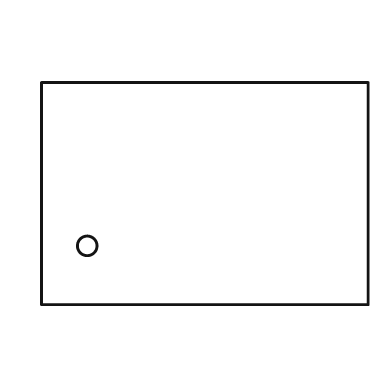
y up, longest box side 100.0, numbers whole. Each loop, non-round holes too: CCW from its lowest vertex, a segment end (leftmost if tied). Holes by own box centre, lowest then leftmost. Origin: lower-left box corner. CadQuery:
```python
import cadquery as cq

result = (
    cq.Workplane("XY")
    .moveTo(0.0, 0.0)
    .lineTo(100.0, 0.0)
    .lineTo(100.0, 68.0)
    .lineTo(0.0, 68.0)
    .close()
    .moveTo(14.0, 18.0)
    .circle(3.0)
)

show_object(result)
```